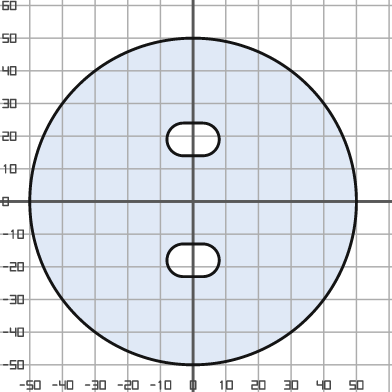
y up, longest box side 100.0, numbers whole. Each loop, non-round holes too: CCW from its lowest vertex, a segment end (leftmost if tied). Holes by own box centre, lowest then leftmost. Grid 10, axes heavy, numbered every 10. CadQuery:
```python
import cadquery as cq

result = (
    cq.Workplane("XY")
    .moveTo(0.0, 0.0)
    .circle(50.0)
    .moveTo(-3.0, -23.0)
    .lineTo(3.0, -23.0)
    .threePointArc((8.0, -18.0), (3.0, -13.0))
    .lineTo(-3.0, -13.0)
    .threePointArc((-8.0, -18.0), (-3.0, -23.0))
    .close()
    .moveTo(-3.0, 14.0)
    .lineTo(3.0, 14.0)
    .threePointArc((8.0, 19.0), (3.0, 24.0))
    .lineTo(-3.0, 24.0)
    .threePointArc((-8.0, 19.0), (-3.0, 14.0))
    .close()
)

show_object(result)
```